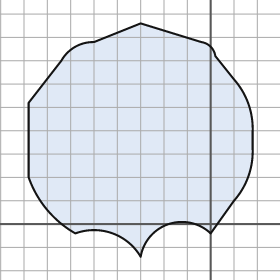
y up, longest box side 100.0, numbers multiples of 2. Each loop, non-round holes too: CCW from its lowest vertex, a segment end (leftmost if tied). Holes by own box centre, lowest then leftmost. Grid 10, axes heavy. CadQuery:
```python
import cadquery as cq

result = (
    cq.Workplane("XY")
    .moveTo(-30.0, -14.0)
    .threePointArc((-18.0, 0.0), (0.0, -4.0))
    .lineTo(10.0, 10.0)
    .threePointArc((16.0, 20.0), (18.0, 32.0))
    .lineTo(18.0, 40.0)
    .threePointArc((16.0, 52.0), (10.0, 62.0))
    .lineTo(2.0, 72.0)
    .threePointArc((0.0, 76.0), (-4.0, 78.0))
    .lineTo(-30.0, 86.0)
    .lineTo(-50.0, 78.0)
    .threePointArc((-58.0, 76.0), (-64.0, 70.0))
    .lineTo(-78.0, 52.0)
    .lineTo(-78.0, 20.0)
    .threePointArc((-70.0, 6.0), (-58.0, -4.0))
    .threePointArc((-42.0, -4.0), (-30.0, -14.0))
    .close()
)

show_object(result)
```